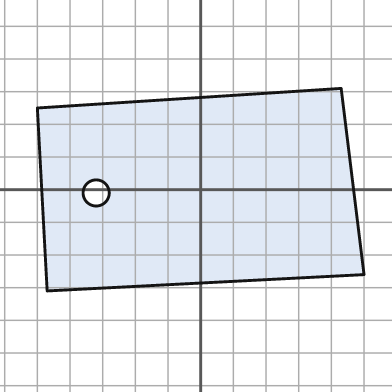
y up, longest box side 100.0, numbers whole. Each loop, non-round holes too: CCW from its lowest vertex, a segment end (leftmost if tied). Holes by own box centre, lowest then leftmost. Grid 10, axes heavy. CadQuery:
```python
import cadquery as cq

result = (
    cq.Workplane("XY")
    .moveTo(-47.0, -31.0)
    .lineTo(50.0, -26.0)
    .lineTo(43.0, 31.0)
    .lineTo(-50.0, 25.0)
    .close()
    .moveTo(-32.0, -1.0)
    .circle(4.0)
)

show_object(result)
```